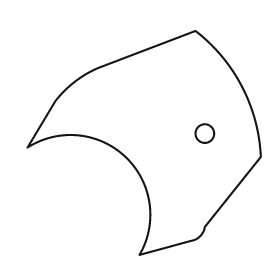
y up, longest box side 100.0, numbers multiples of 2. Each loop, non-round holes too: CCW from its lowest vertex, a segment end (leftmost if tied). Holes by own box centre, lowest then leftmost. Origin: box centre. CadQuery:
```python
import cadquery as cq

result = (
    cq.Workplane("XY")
    .moveTo(-2.0, -48.0)
    .lineTo(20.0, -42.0)
    .threePointArc((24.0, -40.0), (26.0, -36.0))
    .lineTo(50.0, -6.0)
    .threePointArc((42.0, 24.0), (22.0, 48.0))
    .lineTo(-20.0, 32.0)
    .threePointArc((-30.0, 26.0), (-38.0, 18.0))
    .lineTo(-50.0, -2.0)
    .threePointArc((-8.0, -6.0), (-2.0, -48.0))
    .close()
    .moveTo(26.0, 4.0)
    .circle(4.0)
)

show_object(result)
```